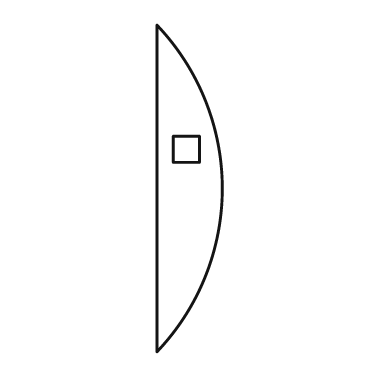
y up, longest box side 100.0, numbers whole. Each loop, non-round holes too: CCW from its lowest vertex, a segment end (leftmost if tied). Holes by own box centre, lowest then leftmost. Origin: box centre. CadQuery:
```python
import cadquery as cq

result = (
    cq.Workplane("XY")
    .moveTo(-10.0, -50.0)
    .threePointArc((10.0, 0.0), (-10.0, 50.0))
    .close()
    .moveTo(-5.0, 8.0)
    .lineTo(3.0, 8.0)
    .lineTo(3.0, 16.0)
    .lineTo(-5.0, 16.0)
    .close()
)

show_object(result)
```